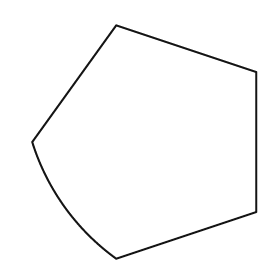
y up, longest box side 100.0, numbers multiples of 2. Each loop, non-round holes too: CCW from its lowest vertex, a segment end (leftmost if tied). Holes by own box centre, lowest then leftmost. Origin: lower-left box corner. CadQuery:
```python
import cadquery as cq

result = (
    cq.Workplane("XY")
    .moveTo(36.0, 0.0)
    .lineTo(96.0, 20.0)
    .lineTo(96.0, 80.0)
    .lineTo(36.0, 100.0)
    .lineTo(0.0, 50.0)
    .threePointArc((14.0, 22.0), (36.0, 0.0))
    .close()
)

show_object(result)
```